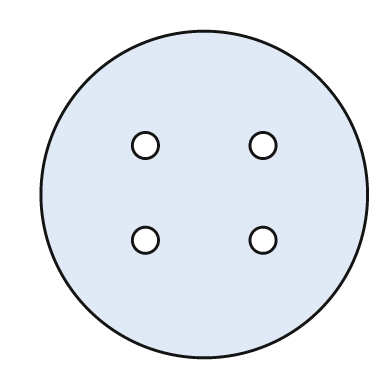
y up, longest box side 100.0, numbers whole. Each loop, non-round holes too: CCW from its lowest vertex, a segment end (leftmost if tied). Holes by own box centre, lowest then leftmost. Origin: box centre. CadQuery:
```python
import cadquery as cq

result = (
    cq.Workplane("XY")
    .moveTo(0.0, 0.0)
    .circle(50.0)
    .moveTo(-18.0, -14.0)
    .circle(4.0)
    .moveTo(18.0, -14.0)
    .circle(4.0)
    .moveTo(-18.0, 15.0)
    .circle(4.0)
    .moveTo(18.0, 15.0)
    .circle(4.0)
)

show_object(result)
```